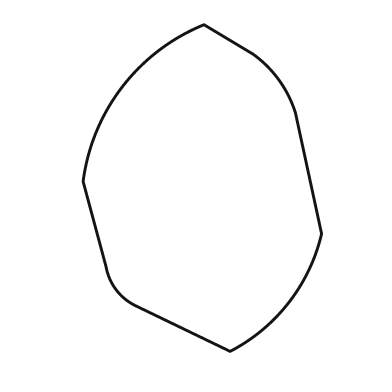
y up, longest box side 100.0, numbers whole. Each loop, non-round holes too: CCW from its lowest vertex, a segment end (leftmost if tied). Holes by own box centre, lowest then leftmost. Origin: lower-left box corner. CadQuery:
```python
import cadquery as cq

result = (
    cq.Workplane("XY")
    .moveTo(45.0, 0.0)
    .threePointArc((63.0, 15.0), (73.0, 36.0))
    .lineTo(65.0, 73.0)
    .threePointArc((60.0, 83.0), (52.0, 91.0))
    .lineTo(37.0, 100.0)
    .threePointArc((12.0, 81.0), (0.0, 52.0))
    .lineTo(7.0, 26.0)
    .threePointArc((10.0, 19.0), (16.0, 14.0))
    .close()
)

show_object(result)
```